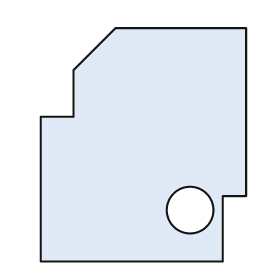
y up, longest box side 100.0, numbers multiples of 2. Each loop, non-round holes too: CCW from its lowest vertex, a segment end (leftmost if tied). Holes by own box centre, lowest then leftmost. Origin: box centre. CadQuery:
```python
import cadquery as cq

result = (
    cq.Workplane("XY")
    .moveTo(-44.0, -50.0)
    .lineTo(34.0, -50.0)
    .lineTo(34.0, -22.0)
    .lineTo(44.0, -22.0)
    .lineTo(44.0, 50.0)
    .lineTo(-12.0, 50.0)
    .lineTo(-30.0, 32.0)
    .lineTo(-30.0, 12.0)
    .lineTo(-44.0, 12.0)
    .close()
    .moveTo(20.0, -28.0)
    .circle(10.0)
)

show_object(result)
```